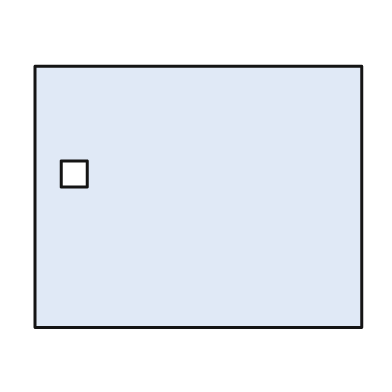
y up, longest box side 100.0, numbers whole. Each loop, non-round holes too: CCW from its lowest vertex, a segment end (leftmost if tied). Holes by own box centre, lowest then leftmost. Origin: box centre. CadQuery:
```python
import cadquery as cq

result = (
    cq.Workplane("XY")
    .moveTo(-50.0, -40.0)
    .lineTo(50.0, -40.0)
    .lineTo(50.0, 40.0)
    .lineTo(-50.0, 40.0)
    .close()
    .moveTo(-42.0, 3.0)
    .lineTo(-34.0, 3.0)
    .lineTo(-34.0, 11.0)
    .lineTo(-42.0, 11.0)
    .close()
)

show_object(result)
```